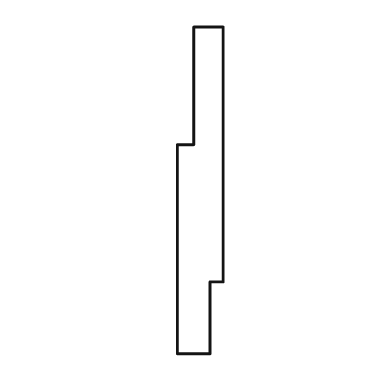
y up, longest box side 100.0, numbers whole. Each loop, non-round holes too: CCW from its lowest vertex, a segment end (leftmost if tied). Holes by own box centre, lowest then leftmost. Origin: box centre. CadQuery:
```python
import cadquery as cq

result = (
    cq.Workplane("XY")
    .moveTo(-7.0, -50.0)
    .lineTo(3.0, -50.0)
    .lineTo(3.0, -28.0)
    .lineTo(7.0, -28.0)
    .lineTo(7.0, 50.0)
    .lineTo(-2.0, 50.0)
    .lineTo(-2.0, 14.0)
    .lineTo(-7.0, 14.0)
    .close()
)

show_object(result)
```